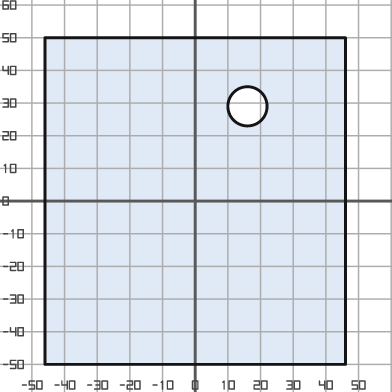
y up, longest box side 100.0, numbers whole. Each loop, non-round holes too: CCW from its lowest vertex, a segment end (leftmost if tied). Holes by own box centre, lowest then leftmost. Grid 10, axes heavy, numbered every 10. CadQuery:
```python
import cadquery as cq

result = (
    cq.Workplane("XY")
    .moveTo(-46.0, -50.0)
    .lineTo(46.0, -50.0)
    .lineTo(46.0, 50.0)
    .lineTo(-46.0, 50.0)
    .close()
    .moveTo(16.0, 29.0)
    .circle(6.0)
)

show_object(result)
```